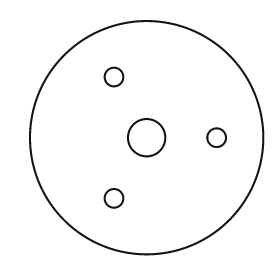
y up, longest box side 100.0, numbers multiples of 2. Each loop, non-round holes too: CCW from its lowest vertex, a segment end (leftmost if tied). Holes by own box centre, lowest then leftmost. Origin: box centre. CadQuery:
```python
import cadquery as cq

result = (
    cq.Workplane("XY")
    .moveTo(0.0, 0.0)
    .circle(50.0)
    .moveTo(-14.0, -26.0)
    .circle(4.0)
    .moveTo(0.0, 0.0)
    .circle(8.0)
    .moveTo(30.0, 0.0)
    .circle(4.0)
    .moveTo(-14.0, 26.0)
    .circle(4.0)
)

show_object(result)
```